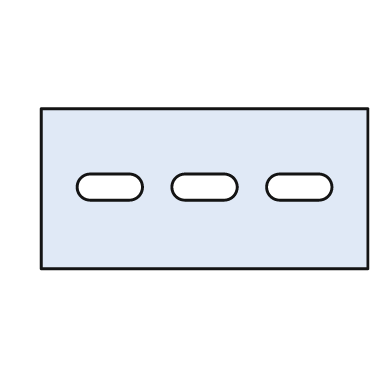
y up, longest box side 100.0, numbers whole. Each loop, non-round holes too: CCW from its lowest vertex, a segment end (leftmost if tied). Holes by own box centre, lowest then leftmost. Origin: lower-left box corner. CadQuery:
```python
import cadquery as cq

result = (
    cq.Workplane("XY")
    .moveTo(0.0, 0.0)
    .lineTo(100.0, 0.0)
    .lineTo(100.0, 49.0)
    .lineTo(0.0, 49.0)
    .close()
    .moveTo(15.0, 21.0)
    .lineTo(27.0, 21.0)
    .threePointArc((31.0, 25.0), (27.0, 29.0))
    .lineTo(15.0, 29.0)
    .threePointArc((11.0, 25.0), (15.0, 21.0))
    .close()
    .moveTo(44.0, 21.0)
    .lineTo(56.0, 21.0)
    .threePointArc((60.0, 25.0), (56.0, 29.0))
    .lineTo(44.0, 29.0)
    .threePointArc((40.0, 25.0), (44.0, 21.0))
    .close()
    .moveTo(73.0, 21.0)
    .lineTo(85.0, 21.0)
    .threePointArc((89.0, 25.0), (85.0, 29.0))
    .lineTo(73.0, 29.0)
    .threePointArc((69.0, 25.0), (73.0, 21.0))
    .close()
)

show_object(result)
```